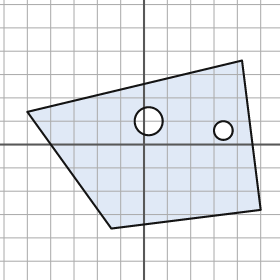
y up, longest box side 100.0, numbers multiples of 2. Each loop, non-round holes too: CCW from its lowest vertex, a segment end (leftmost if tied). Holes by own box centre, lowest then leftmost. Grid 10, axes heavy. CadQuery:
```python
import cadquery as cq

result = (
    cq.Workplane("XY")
    .moveTo(-14.0, -36.0)
    .lineTo(50.0, -28.0)
    .lineTo(42.0, 36.0)
    .lineTo(-50.0, 14.0)
    .close()
    .moveTo(34.0, 6.0)
    .circle(4.0)
    .moveTo(2.0, 10.0)
    .circle(6.0)
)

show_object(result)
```